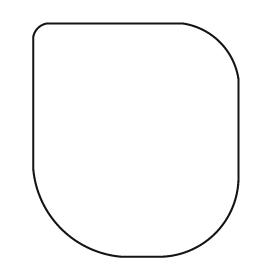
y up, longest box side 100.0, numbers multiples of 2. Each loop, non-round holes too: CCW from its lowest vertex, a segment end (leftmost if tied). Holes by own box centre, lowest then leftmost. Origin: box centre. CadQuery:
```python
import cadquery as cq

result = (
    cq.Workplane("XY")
    .moveTo(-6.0, -50.0)
    .lineTo(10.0, -50.0)
    .threePointArc((34.0, -40.0), (44.0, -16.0))
    .lineTo(44.0, 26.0)
    .threePointArc((36.0, 42.0), (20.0, 50.0))
    .lineTo(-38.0, 50.0)
    .threePointArc((-42.0, 48.0), (-44.0, 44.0))
    .lineTo(-44.0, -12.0)
    .threePointArc((-32.0, -38.0), (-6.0, -50.0))
    .close()
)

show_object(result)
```